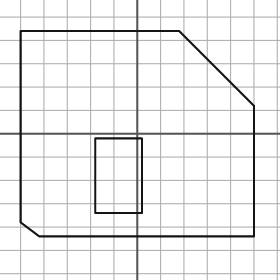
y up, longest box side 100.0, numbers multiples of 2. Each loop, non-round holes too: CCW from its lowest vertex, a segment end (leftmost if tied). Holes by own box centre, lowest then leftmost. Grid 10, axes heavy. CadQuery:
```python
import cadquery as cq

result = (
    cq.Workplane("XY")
    .moveTo(-42.0, -44.0)
    .lineTo(50.0, -44.0)
    .lineTo(50.0, 12.0)
    .lineTo(18.0, 44.0)
    .lineTo(-50.0, 44.0)
    .lineTo(-50.0, -38.0)
    .close()
    .moveTo(-18.0, -34.0)
    .lineTo(2.0, -34.0)
    .lineTo(2.0, -2.0)
    .lineTo(-18.0, -2.0)
    .close()
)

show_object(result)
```